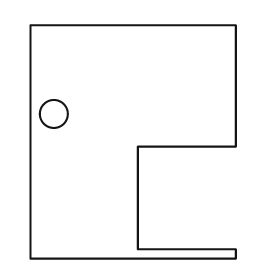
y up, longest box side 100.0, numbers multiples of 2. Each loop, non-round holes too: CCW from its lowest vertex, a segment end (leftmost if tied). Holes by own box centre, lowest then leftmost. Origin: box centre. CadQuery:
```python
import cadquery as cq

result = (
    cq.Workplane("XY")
    .moveTo(-44.0, -50.0)
    .lineTo(44.0, -50.0)
    .lineTo(44.0, -46.0)
    .lineTo(2.0, -46.0)
    .lineTo(2.0, -2.0)
    .lineTo(44.0, -2.0)
    .lineTo(44.0, 50.0)
    .lineTo(-44.0, 50.0)
    .close()
    .moveTo(-34.0, 12.0)
    .circle(6.0)
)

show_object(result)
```